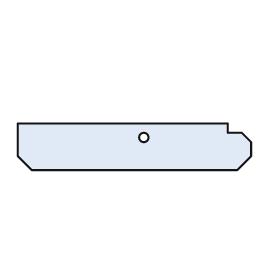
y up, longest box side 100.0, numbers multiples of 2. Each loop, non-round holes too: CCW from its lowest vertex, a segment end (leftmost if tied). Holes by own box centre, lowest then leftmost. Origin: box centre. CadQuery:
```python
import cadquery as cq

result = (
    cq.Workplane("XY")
    .moveTo(-44.0, -10.0)
    .lineTo(44.0, -10.0)
    .lineTo(50.0, -4.0)
    .lineTo(50.0, 2.0)
    .lineTo(46.0, 6.0)
    .lineTo(40.0, 6.0)
    .lineTo(40.0, 10.0)
    .lineTo(-50.0, 10.0)
    .lineTo(-50.0, -4.0)
    .close()
    .moveTo(4.0, 4.0)
    .circle(2.0)
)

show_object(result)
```